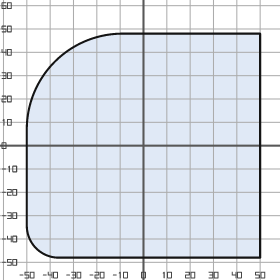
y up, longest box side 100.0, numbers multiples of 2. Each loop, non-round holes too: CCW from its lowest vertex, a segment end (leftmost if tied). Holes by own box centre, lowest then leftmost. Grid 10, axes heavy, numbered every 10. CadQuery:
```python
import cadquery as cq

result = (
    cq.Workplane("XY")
    .moveTo(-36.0, -48.0)
    .lineTo(50.0, -48.0)
    .lineTo(50.0, 48.0)
    .lineTo(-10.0, 48.0)
    .threePointArc((-38.0, 36.0), (-50.0, 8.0))
    .lineTo(-50.0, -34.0)
    .threePointArc((-46.0, -44.0), (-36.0, -48.0))
    .close()
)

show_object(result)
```